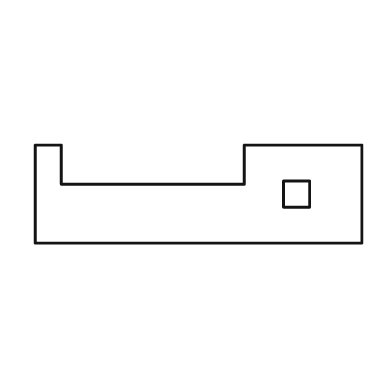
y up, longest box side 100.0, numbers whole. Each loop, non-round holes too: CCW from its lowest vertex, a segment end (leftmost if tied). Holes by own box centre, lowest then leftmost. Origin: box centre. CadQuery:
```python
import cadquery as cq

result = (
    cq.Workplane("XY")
    .moveTo(-50.0, -15.0)
    .lineTo(50.0, -15.0)
    .lineTo(50.0, 15.0)
    .lineTo(14.0, 15.0)
    .lineTo(14.0, 3.0)
    .lineTo(-42.0, 3.0)
    .lineTo(-42.0, 15.0)
    .lineTo(-50.0, 15.0)
    .close()
    .moveTo(26.0, -4.0)
    .lineTo(34.0, -4.0)
    .lineTo(34.0, 4.0)
    .lineTo(26.0, 4.0)
    .close()
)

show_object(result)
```